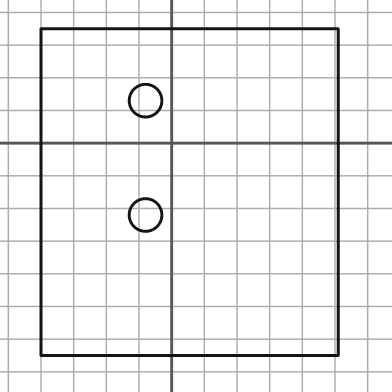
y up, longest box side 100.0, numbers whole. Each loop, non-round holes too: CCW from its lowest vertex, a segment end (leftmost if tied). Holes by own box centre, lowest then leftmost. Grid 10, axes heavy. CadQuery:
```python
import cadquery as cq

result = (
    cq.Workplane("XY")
    .moveTo(-40.0, -65.0)
    .lineTo(51.0, -65.0)
    .lineTo(51.0, 35.0)
    .lineTo(-40.0, 35.0)
    .close()
    .moveTo(-8.0, -22.0)
    .circle(5.0)
    .moveTo(-8.0, 13.0)
    .circle(5.0)
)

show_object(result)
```